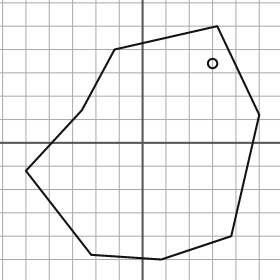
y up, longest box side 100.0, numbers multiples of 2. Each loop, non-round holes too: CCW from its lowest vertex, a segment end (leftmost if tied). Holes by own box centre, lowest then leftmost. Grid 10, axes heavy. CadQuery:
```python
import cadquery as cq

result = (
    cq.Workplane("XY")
    .moveTo(8.0, -50.0)
    .lineTo(38.0, -40.0)
    .lineTo(50.0, 12.0)
    .lineTo(32.0, 50.0)
    .lineTo(-12.0, 40.0)
    .lineTo(-26.0, 14.0)
    .lineTo(-50.0, -12.0)
    .lineTo(-22.0, -48.0)
    .close()
    .moveTo(30.0, 34.0)
    .circle(2.0)
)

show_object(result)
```